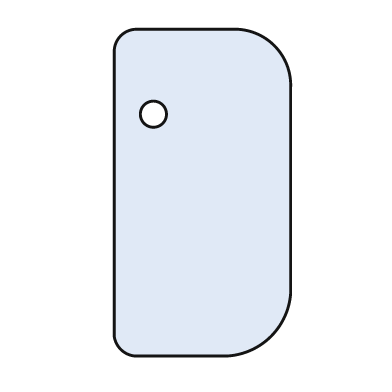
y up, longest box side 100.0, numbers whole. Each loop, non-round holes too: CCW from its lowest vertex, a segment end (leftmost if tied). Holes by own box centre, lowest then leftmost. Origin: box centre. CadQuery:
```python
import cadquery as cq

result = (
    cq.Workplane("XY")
    .moveTo(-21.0, -50.0)
    .lineTo(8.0, -50.0)
    .threePointArc((21.0, -44.0), (27.0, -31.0))
    .lineTo(27.0, 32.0)
    .threePointArc((22.0, 45.0), (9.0, 50.0))
    .lineTo(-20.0, 50.0)
    .threePointArc((-25.0, 48.0), (-27.0, 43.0))
    .lineTo(-27.0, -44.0)
    .threePointArc((-25.0, -48.0), (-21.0, -50.0))
    .close()
    .moveTo(-15.0, 24.0)
    .circle(4.0)
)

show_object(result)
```